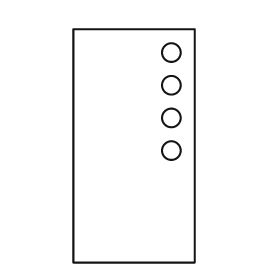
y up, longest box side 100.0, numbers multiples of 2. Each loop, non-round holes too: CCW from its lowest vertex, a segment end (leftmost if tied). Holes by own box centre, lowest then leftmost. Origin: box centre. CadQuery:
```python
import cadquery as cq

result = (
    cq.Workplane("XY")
    .moveTo(-26.0, -50.0)
    .lineTo(26.0, -50.0)
    .lineTo(26.0, 50.0)
    .lineTo(-26.0, 50.0)
    .close()
    .moveTo(16.0, -2.0)
    .circle(4.0)
    .moveTo(16.0, 12.0)
    .circle(4.0)
    .moveTo(16.0, 26.0)
    .circle(4.0)
    .moveTo(16.0, 40.0)
    .circle(4.0)
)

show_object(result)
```